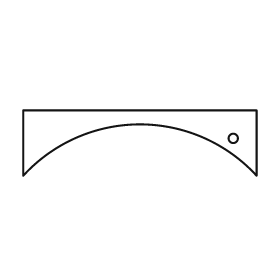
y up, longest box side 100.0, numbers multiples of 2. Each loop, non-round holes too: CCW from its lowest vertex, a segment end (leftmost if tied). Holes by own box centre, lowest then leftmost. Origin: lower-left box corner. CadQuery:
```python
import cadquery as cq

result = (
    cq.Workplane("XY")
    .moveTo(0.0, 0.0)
    .threePointArc((50.0, 22.0), (100.0, 0.0))
    .lineTo(100.0, 28.0)
    .lineTo(0.0, 28.0)
    .close()
    .moveTo(90.0, 16.0)
    .circle(2.0)
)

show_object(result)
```